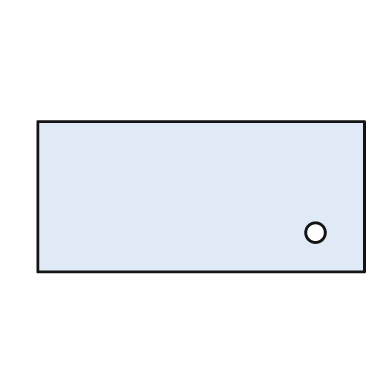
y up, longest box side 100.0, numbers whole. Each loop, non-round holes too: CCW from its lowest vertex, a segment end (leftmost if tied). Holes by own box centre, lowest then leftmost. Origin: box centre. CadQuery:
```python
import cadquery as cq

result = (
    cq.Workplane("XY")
    .moveTo(-50.0, -23.0)
    .lineTo(50.0, -23.0)
    .lineTo(50.0, 23.0)
    .lineTo(-50.0, 23.0)
    .close()
    .moveTo(35.0, -11.0)
    .circle(3.0)
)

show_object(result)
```